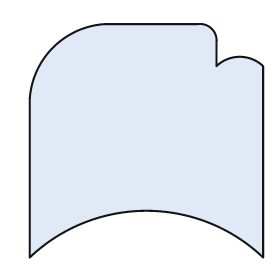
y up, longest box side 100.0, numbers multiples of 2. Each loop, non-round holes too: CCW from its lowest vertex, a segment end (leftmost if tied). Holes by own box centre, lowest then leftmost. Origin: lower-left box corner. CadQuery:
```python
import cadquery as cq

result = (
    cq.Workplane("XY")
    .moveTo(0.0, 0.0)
    .threePointArc((50.0, 20.0), (100.0, 0.0))
    .lineTo(100.0, 82.0)
    .threePointArc((90.0, 86.0), (80.0, 82.0))
    .lineTo(80.0, 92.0)
    .threePointArc((78.0, 98.0), (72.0, 100.0))
    .lineTo(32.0, 100.0)
    .threePointArc((10.0, 90.0), (0.0, 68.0))
    .close()
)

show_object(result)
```